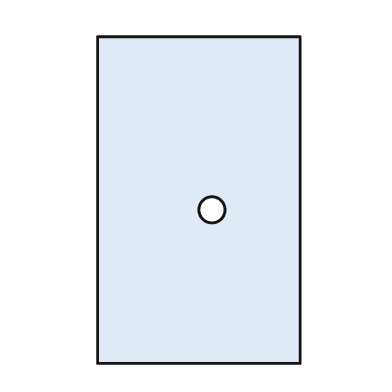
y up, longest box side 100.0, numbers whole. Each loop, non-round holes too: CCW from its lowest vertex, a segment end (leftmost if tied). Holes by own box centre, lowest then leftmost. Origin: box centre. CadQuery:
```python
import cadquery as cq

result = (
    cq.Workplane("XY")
    .moveTo(-31.0, -50.0)
    .lineTo(31.0, -50.0)
    .lineTo(31.0, 50.0)
    .lineTo(-31.0, 50.0)
    .close()
    .moveTo(4.0, -3.0)
    .circle(4.0)
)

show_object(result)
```